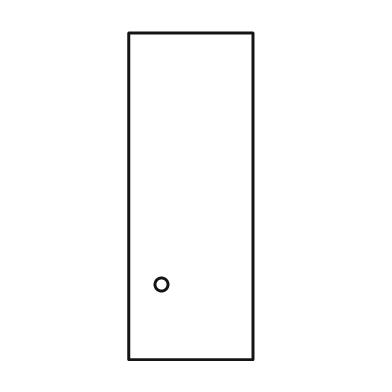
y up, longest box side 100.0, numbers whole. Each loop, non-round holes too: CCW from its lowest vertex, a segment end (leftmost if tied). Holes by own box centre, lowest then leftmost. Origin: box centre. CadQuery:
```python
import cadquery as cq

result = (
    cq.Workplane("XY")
    .moveTo(-19.0, -50.0)
    .lineTo(19.0, -50.0)
    .lineTo(19.0, 50.0)
    .lineTo(-19.0, 50.0)
    .close()
    .moveTo(-9.0, -27.0)
    .circle(2.0)
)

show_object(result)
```